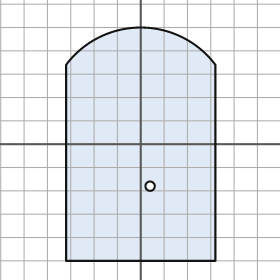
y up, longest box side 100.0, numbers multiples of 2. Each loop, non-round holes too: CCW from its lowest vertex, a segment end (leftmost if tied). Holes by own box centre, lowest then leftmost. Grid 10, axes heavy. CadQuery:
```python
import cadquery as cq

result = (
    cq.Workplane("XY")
    .moveTo(-32.0, -50.0)
    .lineTo(32.0, -50.0)
    .lineTo(32.0, 34.0)
    .threePointArc((0.0, 50.0), (-32.0, 34.0))
    .close()
    .moveTo(4.0, -18.0)
    .circle(2.0)
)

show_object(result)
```